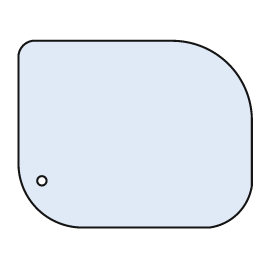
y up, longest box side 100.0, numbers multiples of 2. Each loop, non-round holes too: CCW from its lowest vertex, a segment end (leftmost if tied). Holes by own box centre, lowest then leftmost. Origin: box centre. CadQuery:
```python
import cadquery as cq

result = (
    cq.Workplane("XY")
    .moveTo(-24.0, -40.0)
    .lineTo(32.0, -40.0)
    .threePointArc((44.0, -34.0), (50.0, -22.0))
    .lineTo(50.0, 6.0)
    .threePointArc((40.0, 30.0), (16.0, 40.0))
    .lineTo(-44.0, 40.0)
    .threePointArc((-48.0, 38.0), (-50.0, 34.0))
    .lineTo(-50.0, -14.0)
    .threePointArc((-42.0, -32.0), (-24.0, -40.0))
    .close()
    .moveTo(-40.0, -20.0)
    .circle(2.0)
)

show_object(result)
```